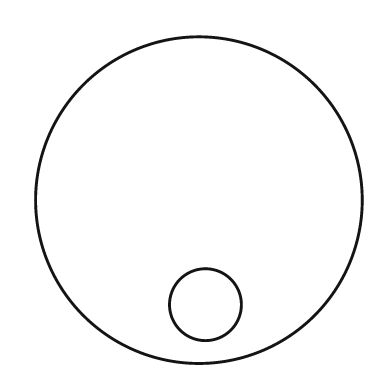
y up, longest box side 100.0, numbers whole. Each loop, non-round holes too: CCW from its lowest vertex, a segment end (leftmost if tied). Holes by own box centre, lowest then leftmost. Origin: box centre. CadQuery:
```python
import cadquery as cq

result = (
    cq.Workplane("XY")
    .moveTo(0.0, 0.0)
    .circle(50.0)
    .moveTo(2.0, -32.0)
    .circle(11.0)
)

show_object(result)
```